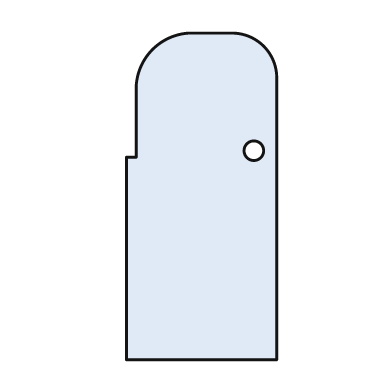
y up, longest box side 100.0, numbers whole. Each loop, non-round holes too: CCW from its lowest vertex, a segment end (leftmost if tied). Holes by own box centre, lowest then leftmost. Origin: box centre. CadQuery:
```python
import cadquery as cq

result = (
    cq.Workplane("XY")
    .moveTo(-23.0, -50.0)
    .lineTo(23.0, -50.0)
    .lineTo(23.0, 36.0)
    .threePointArc((19.0, 46.0), (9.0, 50.0))
    .lineTo(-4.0, 50.0)
    .threePointArc((-15.0, 45.0), (-20.0, 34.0))
    .lineTo(-20.0, 12.0)
    .lineTo(-23.0, 12.0)
    .close()
    .moveTo(16.0, 14.0)
    .circle(3.0)
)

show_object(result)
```